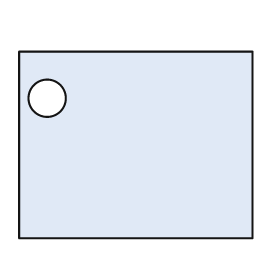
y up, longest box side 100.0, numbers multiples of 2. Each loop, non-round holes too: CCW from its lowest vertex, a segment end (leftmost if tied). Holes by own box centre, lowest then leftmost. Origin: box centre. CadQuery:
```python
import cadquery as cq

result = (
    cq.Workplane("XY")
    .moveTo(-50.0, -40.0)
    .lineTo(50.0, -40.0)
    .lineTo(50.0, 40.0)
    .lineTo(-50.0, 40.0)
    .close()
    .moveTo(-38.0, 20.0)
    .circle(8.0)
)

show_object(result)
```